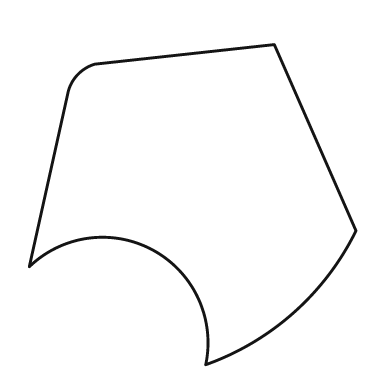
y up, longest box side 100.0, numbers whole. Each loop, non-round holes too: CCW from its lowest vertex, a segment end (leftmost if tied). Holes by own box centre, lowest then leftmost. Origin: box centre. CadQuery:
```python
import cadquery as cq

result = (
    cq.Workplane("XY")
    .moveTo(4.0, -49.0)
    .threePointArc((31.0, -33.0), (50.0, -8.0))
    .lineTo(25.0, 49.0)
    .lineTo(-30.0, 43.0)
    .threePointArc((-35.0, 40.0), (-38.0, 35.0))
    .lineTo(-50.0, -19.0)
    .threePointArc((-12.0, -14.0), (4.0, -49.0))
    .close()
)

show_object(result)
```